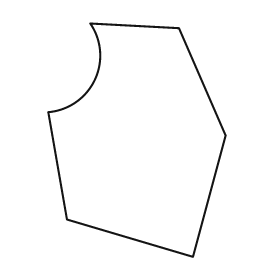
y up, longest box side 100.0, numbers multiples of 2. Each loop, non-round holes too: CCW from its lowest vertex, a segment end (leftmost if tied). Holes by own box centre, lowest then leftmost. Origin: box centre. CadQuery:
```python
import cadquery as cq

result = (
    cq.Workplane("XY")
    .moveTo(24.0, -50.0)
    .lineTo(38.0, 2.0)
    .lineTo(18.0, 48.0)
    .lineTo(-20.0, 50.0)
    .threePointArc((-18.0, 26.0), (-38.0, 12.0))
    .lineTo(-30.0, -34.0)
    .close()
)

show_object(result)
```